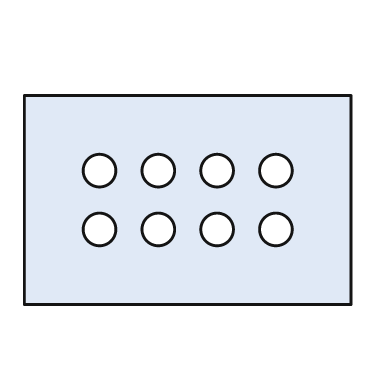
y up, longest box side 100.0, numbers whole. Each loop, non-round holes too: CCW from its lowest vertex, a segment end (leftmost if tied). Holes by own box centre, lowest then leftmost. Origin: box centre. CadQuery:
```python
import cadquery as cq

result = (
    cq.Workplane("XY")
    .moveTo(-50.0, -32.0)
    .lineTo(50.0, -32.0)
    .lineTo(50.0, 32.0)
    .lineTo(-50.0, 32.0)
    .close()
    .moveTo(-27.0, -9.0)
    .circle(5.0)
    .moveTo(-9.0, -9.0)
    .circle(5.0)
    .moveTo(9.0, -9.0)
    .circle(5.0)
    .moveTo(27.0, -9.0)
    .circle(5.0)
    .moveTo(-27.0, 9.0)
    .circle(5.0)
    .moveTo(-9.0, 9.0)
    .circle(5.0)
    .moveTo(9.0, 9.0)
    .circle(5.0)
    .moveTo(27.0, 9.0)
    .circle(5.0)
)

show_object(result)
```